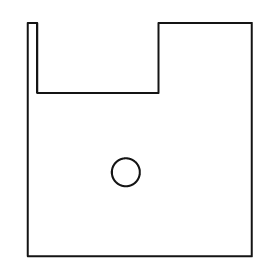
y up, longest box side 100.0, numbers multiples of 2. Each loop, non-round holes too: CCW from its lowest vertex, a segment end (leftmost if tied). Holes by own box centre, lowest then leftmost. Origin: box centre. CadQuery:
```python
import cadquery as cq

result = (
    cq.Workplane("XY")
    .moveTo(-48.0, -50.0)
    .lineTo(48.0, -50.0)
    .lineTo(48.0, 50.0)
    .lineTo(8.0, 50.0)
    .lineTo(8.0, 20.0)
    .lineTo(-44.0, 20.0)
    .lineTo(-44.0, 50.0)
    .lineTo(-48.0, 50.0)
    .close()
    .moveTo(-6.0, -14.0)
    .circle(6.0)
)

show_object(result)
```